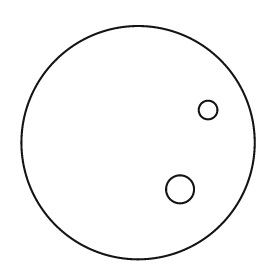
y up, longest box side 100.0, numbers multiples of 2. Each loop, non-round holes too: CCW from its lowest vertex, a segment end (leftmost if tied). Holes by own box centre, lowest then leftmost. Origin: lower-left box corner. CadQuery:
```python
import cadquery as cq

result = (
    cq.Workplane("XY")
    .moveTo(50.0, 50.0)
    .circle(50.0)
    .moveTo(68.0, 30.0)
    .circle(6.0)
    .moveTo(80.0, 64.0)
    .circle(4.0)
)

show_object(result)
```